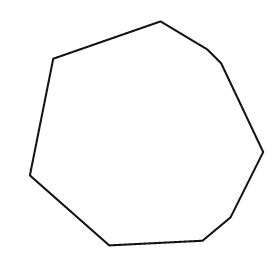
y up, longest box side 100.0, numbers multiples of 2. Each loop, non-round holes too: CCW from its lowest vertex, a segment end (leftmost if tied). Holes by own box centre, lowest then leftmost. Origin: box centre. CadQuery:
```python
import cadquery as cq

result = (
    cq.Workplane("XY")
    .moveTo(-16.0, -48.0)
    .lineTo(24.0, -46.0)
    .lineTo(36.0, -36.0)
    .lineTo(50.0, -8.0)
    .lineTo(32.0, 30.0)
    .lineTo(26.0, 36.0)
    .lineTo(6.0, 48.0)
    .lineTo(-40.0, 32.0)
    .lineTo(-50.0, -18.0)
    .close()
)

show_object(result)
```